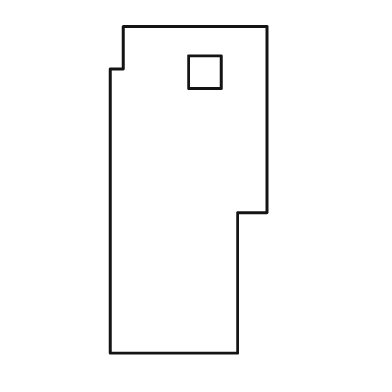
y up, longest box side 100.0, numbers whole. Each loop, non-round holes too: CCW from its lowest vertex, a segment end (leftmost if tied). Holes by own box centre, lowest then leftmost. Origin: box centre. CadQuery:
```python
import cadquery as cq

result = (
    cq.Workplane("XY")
    .moveTo(-24.0, -50.0)
    .lineTo(15.0, -50.0)
    .lineTo(15.0, -7.0)
    .lineTo(24.0, -7.0)
    .lineTo(24.0, 50.0)
    .lineTo(-20.0, 50.0)
    .lineTo(-20.0, 37.0)
    .lineTo(-24.0, 37.0)
    .close()
    .moveTo(0.0, 31.0)
    .lineTo(10.0, 31.0)
    .lineTo(10.0, 41.0)
    .lineTo(0.0, 41.0)
    .close()
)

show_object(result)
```